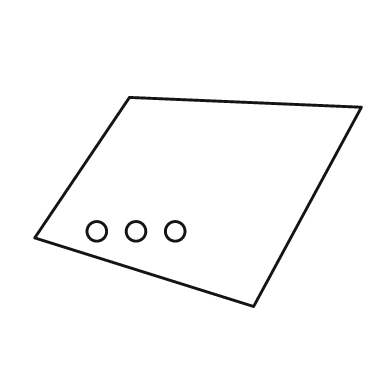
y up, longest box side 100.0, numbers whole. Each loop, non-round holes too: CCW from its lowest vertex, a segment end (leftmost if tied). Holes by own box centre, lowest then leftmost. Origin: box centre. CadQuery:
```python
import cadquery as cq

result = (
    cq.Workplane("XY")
    .moveTo(17.0, -32.0)
    .lineTo(50.0, 29.0)
    .lineTo(-21.0, 32.0)
    .lineTo(-50.0, -11.0)
    .close()
    .moveTo(-31.0, -9.0)
    .circle(3.0)
    .moveTo(-19.0, -9.0)
    .circle(3.0)
    .moveTo(-7.0, -9.0)
    .circle(3.0)
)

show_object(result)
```